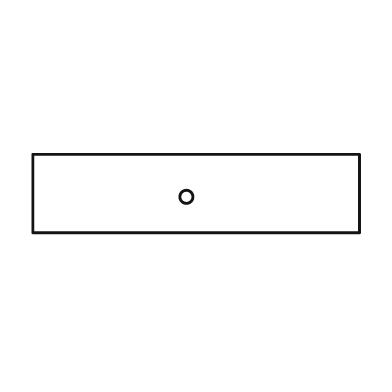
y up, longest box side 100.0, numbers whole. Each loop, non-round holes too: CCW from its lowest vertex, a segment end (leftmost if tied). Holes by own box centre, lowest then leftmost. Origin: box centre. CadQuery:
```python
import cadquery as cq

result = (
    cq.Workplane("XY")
    .moveTo(-50.0, -12.0)
    .lineTo(50.0, -12.0)
    .lineTo(50.0, 12.0)
    .lineTo(-50.0, 12.0)
    .close()
    .moveTo(-3.0, -1.0)
    .circle(2.0)
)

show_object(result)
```